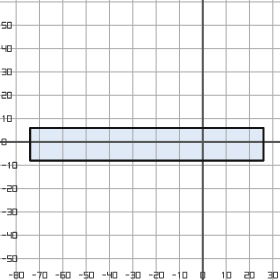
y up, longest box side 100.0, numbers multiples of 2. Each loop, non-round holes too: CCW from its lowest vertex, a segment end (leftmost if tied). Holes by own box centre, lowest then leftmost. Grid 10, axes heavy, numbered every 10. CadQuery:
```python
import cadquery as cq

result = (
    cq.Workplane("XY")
    .moveTo(-74.0, -8.0)
    .lineTo(26.0, -8.0)
    .lineTo(26.0, 6.0)
    .lineTo(-74.0, 6.0)
    .close()
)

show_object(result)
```